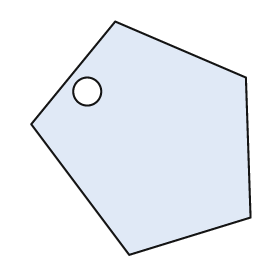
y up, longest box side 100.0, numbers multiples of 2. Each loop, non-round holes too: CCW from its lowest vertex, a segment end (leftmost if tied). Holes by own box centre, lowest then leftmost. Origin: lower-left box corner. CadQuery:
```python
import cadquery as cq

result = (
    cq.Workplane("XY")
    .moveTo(42.0, 0.0)
    .lineTo(94.0, 16.0)
    .lineTo(92.0, 76.0)
    .lineTo(36.0, 100.0)
    .lineTo(0.0, 56.0)
    .close()
    .moveTo(24.0, 70.0)
    .circle(6.0)
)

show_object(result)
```